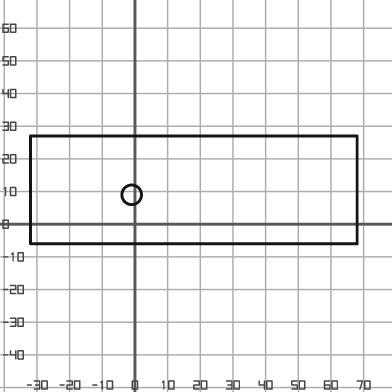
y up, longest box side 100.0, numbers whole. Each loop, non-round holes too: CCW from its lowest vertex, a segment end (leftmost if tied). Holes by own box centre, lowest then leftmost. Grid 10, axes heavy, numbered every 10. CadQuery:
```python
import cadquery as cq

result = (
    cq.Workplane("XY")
    .moveTo(-32.0, -6.0)
    .lineTo(68.0, -6.0)
    .lineTo(68.0, 27.0)
    .lineTo(-32.0, 27.0)
    .close()
    .moveTo(-1.0, 9.0)
    .circle(3.0)
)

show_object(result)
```